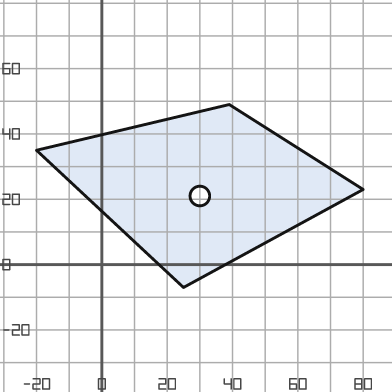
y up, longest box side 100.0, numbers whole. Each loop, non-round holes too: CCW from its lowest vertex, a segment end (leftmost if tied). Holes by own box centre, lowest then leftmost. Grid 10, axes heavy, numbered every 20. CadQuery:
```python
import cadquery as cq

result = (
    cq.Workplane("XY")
    .moveTo(25.0, -7.0)
    .lineTo(80.0, 23.0)
    .lineTo(39.0, 49.0)
    .lineTo(-20.0, 35.0)
    .close()
    .moveTo(30.0, 21.0)
    .circle(3.0)
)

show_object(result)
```